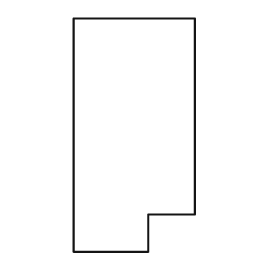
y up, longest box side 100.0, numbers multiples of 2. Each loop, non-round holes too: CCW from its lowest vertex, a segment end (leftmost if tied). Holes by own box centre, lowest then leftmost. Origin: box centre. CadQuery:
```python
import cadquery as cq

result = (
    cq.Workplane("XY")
    .moveTo(-26.0, -50.0)
    .lineTo(6.0, -50.0)
    .lineTo(6.0, -34.0)
    .lineTo(26.0, -34.0)
    .lineTo(26.0, 50.0)
    .lineTo(-26.0, 50.0)
    .close()
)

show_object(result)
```